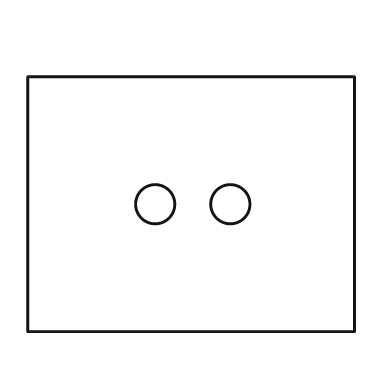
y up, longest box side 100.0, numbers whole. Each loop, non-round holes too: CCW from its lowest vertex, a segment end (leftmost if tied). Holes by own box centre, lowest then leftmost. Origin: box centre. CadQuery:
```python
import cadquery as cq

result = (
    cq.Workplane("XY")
    .moveTo(-50.0, -39.0)
    .lineTo(50.0, -39.0)
    .lineTo(50.0, 39.0)
    .lineTo(-50.0, 39.0)
    .close()
    .moveTo(-11.0, 0.0)
    .circle(6.0)
    .moveTo(12.0, 0.0)
    .circle(6.0)
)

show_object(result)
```